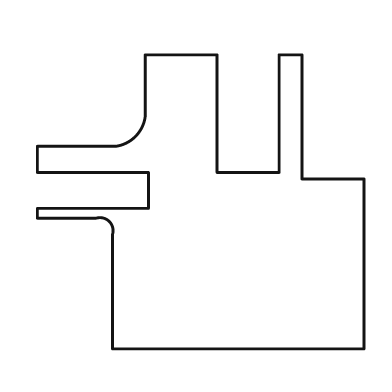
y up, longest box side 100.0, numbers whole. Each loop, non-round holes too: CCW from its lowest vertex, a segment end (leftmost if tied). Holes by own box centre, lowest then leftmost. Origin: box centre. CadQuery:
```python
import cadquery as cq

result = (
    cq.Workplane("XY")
    .moveTo(-27.0, -45.0)
    .lineTo(50.0, -45.0)
    .lineTo(50.0, 7.0)
    .lineTo(31.0, 7.0)
    .lineTo(31.0, 45.0)
    .lineTo(24.0, 45.0)
    .lineTo(24.0, 9.0)
    .lineTo(5.0, 9.0)
    .lineTo(5.0, 45.0)
    .lineTo(-17.0, 45.0)
    .lineTo(-17.0, 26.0)
    .threePointArc((-20.0, 20.0), (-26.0, 17.0))
    .lineTo(-50.0, 17.0)
    .lineTo(-50.0, 9.0)
    .lineTo(-16.0, 9.0)
    .lineTo(-16.0, -2.0)
    .lineTo(-50.0, -2.0)
    .lineTo(-50.0, -5.0)
    .lineTo(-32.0, -5.0)
    .threePointArc((-28.0, -6.0), (-27.0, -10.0))
    .close()
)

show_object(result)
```